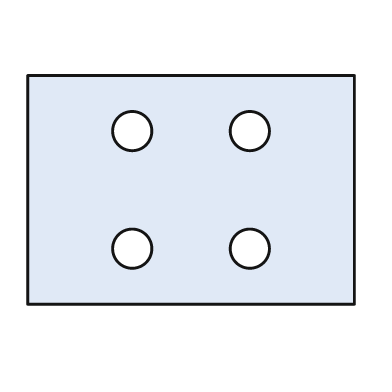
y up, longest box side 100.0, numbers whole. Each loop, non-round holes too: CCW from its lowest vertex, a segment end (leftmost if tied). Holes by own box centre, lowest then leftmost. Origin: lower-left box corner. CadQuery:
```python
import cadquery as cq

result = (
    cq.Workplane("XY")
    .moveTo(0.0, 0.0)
    .lineTo(100.0, 0.0)
    .lineTo(100.0, 70.0)
    .lineTo(0.0, 70.0)
    .close()
    .moveTo(32.0, 17.0)
    .circle(6.0)
    .moveTo(68.0, 17.0)
    .circle(6.0)
    .moveTo(32.0, 53.0)
    .circle(6.0)
    .moveTo(68.0, 53.0)
    .circle(6.0)
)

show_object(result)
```